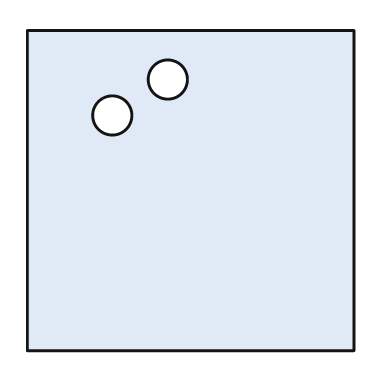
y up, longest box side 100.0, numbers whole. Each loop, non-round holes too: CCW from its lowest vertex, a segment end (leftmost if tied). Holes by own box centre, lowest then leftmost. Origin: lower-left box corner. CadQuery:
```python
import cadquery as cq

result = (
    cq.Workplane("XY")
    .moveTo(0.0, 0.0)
    .lineTo(100.0, 0.0)
    .lineTo(100.0, 98.0)
    .lineTo(0.0, 98.0)
    .close()
    .moveTo(26.0, 72.0)
    .circle(6.0)
    .moveTo(43.0, 83.0)
    .circle(6.0)
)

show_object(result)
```